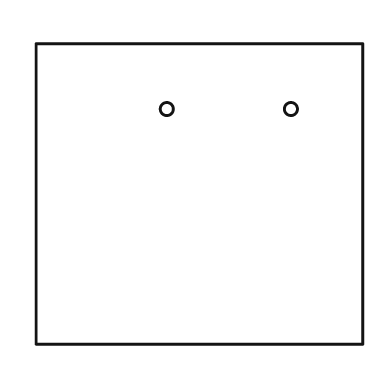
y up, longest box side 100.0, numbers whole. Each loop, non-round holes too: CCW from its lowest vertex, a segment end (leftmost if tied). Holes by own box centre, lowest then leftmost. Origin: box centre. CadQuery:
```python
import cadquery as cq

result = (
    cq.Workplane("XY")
    .moveTo(-50.0, -46.0)
    .lineTo(50.0, -46.0)
    .lineTo(50.0, 46.0)
    .lineTo(-50.0, 46.0)
    .close()
    .moveTo(-10.0, 26.0)
    .circle(2.0)
    .moveTo(28.0, 26.0)
    .circle(2.0)
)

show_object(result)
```